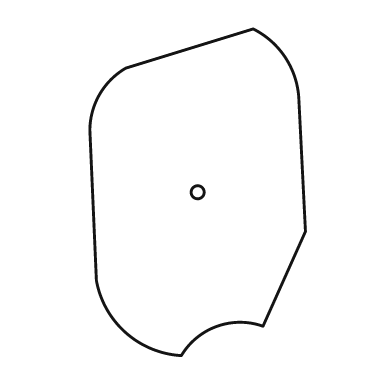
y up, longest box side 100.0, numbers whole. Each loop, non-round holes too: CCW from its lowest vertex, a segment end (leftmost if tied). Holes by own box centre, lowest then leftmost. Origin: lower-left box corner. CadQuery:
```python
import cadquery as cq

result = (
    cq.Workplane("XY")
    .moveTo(28.0, 0.0)
    .threePointArc((39.0, 9.0), (53.0, 9.0))
    .lineTo(66.0, 38.0)
    .lineTo(64.0, 78.0)
    .threePointArc((60.0, 91.0), (50.0, 100.0))
    .lineTo(11.0, 88.0)
    .threePointArc((3.0, 80.0), (0.0, 69.0))
    .lineTo(2.0, 23.0)
    .threePointArc((11.0, 7.0), (28.0, 0.0))
    .close()
    .moveTo(33.0, 50.0)
    .circle(2.0)
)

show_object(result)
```